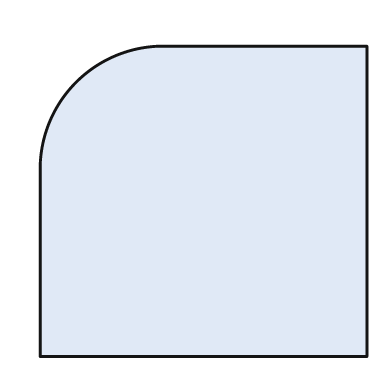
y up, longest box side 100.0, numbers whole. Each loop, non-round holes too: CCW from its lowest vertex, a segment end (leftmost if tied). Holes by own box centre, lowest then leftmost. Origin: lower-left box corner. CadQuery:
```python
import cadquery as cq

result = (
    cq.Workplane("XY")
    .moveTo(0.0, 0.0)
    .lineTo(100.0, 0.0)
    .lineTo(100.0, 95.0)
    .lineTo(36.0, 95.0)
    .threePointArc((11.0, 84.0), (0.0, 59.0))
    .close()
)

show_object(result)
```